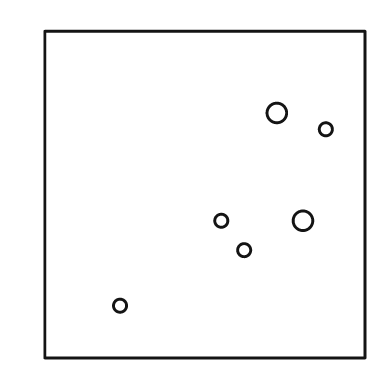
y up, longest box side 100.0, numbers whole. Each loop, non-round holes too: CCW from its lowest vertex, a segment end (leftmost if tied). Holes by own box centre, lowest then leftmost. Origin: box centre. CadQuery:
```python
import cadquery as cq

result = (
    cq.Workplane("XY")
    .moveTo(-49.0, -50.0)
    .lineTo(49.0, -50.0)
    .lineTo(49.0, 50.0)
    .lineTo(-49.0, 50.0)
    .close()
    .moveTo(-26.0, -34.0)
    .circle(2.0)
    .moveTo(12.0, -17.0)
    .circle(2.0)
    .moveTo(5.0, -8.0)
    .circle(2.0)
    .moveTo(30.0, -8.0)
    .circle(3.0)
    .moveTo(37.0, 20.0)
    .circle(2.0)
    .moveTo(22.0, 25.0)
    .circle(3.0)
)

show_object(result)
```